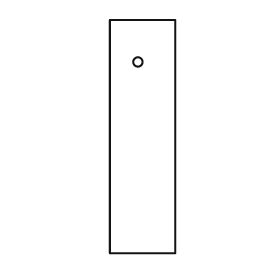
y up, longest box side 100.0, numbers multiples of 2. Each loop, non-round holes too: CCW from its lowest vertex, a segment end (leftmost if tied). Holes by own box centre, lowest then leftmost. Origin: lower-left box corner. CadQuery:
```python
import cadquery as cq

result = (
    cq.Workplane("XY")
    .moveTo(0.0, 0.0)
    .lineTo(28.0, 0.0)
    .lineTo(28.0, 100.0)
    .lineTo(0.0, 100.0)
    .close()
    .moveTo(12.0, 82.0)
    .circle(2.0)
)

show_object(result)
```